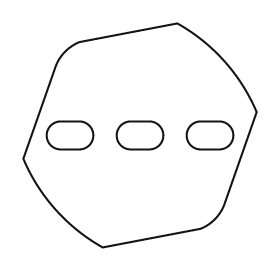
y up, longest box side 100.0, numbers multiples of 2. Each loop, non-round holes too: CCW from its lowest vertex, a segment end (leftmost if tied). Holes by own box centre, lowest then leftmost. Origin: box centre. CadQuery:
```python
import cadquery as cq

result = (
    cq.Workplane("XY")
    .moveTo(-16.0, -48.0)
    .lineTo(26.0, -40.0)
    .threePointArc((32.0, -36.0), (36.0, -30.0))
    .lineTo(50.0, 10.0)
    .threePointArc((36.0, 32.0), (16.0, 48.0))
    .lineTo(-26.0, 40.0)
    .threePointArc((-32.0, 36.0), (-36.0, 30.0))
    .lineTo(-50.0, -10.0)
    .threePointArc((-36.0, -32.0), (-16.0, -48.0))
    .close()
    .moveTo(-34.0, -6.0)
    .lineTo(-26.0, -6.0)
    .threePointArc((-20.0, 0.0), (-26.0, 6.0))
    .lineTo(-34.0, 6.0)
    .threePointArc((-40.0, 0.0), (-34.0, -6.0))
    .close()
    .moveTo(-4.0, -6.0)
    .lineTo(4.0, -6.0)
    .threePointArc((10.0, 0.0), (4.0, 6.0))
    .lineTo(-4.0, 6.0)
    .threePointArc((-10.0, 0.0), (-4.0, -6.0))
    .close()
    .moveTo(26.0, -6.0)
    .lineTo(34.0, -6.0)
    .threePointArc((40.0, 0.0), (34.0, 6.0))
    .lineTo(26.0, 6.0)
    .threePointArc((20.0, 0.0), (26.0, -6.0))
    .close()
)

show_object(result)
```